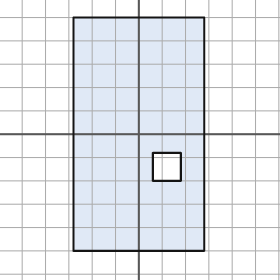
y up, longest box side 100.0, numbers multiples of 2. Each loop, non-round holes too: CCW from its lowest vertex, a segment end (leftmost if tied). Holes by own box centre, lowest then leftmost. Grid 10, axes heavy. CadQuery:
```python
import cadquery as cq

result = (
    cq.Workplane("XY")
    .moveTo(-28.0, -50.0)
    .lineTo(28.0, -50.0)
    .lineTo(28.0, 50.0)
    .lineTo(-28.0, 50.0)
    .close()
    .moveTo(6.0, -20.0)
    .lineTo(18.0, -20.0)
    .lineTo(18.0, -8.0)
    .lineTo(6.0, -8.0)
    .close()
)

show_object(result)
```